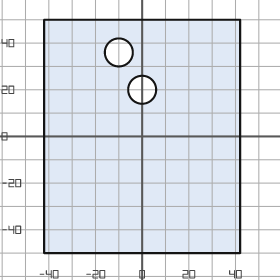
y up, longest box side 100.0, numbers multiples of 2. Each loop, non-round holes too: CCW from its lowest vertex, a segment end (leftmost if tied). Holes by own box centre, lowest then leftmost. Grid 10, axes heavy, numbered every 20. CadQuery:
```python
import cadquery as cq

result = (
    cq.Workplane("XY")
    .moveTo(-42.0, -50.0)
    .lineTo(42.0, -50.0)
    .lineTo(42.0, 50.0)
    .lineTo(-42.0, 50.0)
    .close()
    .moveTo(0.0, 20.0)
    .circle(6.0)
    .moveTo(-10.0, 36.0)
    .circle(6.0)
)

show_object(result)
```